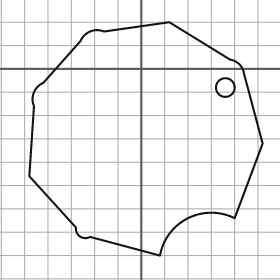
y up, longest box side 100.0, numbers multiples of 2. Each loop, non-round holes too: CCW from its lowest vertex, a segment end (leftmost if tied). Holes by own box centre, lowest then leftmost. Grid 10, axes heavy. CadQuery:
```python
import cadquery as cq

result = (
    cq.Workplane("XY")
    .moveTo(8.0, -80.0)
    .threePointArc((20.0, -64.0), (40.0, -64.0))
    .lineTo(52.0, -32.0)
    .lineTo(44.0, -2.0)
    .threePointArc((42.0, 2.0), (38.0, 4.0))
    .lineTo(12.0, 20.0)
    .lineTo(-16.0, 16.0)
    .threePointArc((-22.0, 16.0), (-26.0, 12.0))
    .lineTo(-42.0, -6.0)
    .threePointArc((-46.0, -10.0), (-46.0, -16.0))
    .lineTo(-48.0, -46.0)
    .lineTo(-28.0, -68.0)
    .threePointArc((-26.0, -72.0), (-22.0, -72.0))
    .close()
    .moveTo(36.0, -8.0)
    .circle(4.0)
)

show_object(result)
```